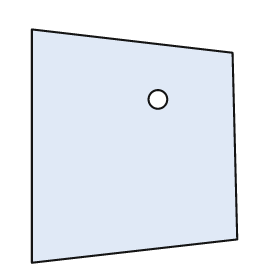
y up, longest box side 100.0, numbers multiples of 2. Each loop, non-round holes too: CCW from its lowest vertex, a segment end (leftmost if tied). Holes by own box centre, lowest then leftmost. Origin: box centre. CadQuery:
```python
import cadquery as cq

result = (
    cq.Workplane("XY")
    .moveTo(-44.0, -50.0)
    .lineTo(44.0, -40.0)
    .lineTo(42.0, 40.0)
    .lineTo(-44.0, 50.0)
    .close()
    .moveTo(10.0, 20.0)
    .circle(4.0)
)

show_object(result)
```